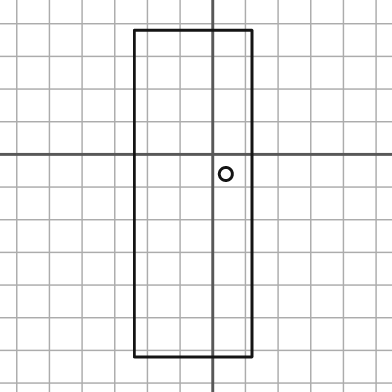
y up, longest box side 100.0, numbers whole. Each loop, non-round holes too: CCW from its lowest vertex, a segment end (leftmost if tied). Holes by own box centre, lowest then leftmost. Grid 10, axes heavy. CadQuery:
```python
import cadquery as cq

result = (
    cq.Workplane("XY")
    .moveTo(-24.0, -62.0)
    .lineTo(12.0, -62.0)
    .lineTo(12.0, 38.0)
    .lineTo(-24.0, 38.0)
    .close()
    .moveTo(4.0, -6.0)
    .circle(2.0)
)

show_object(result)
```